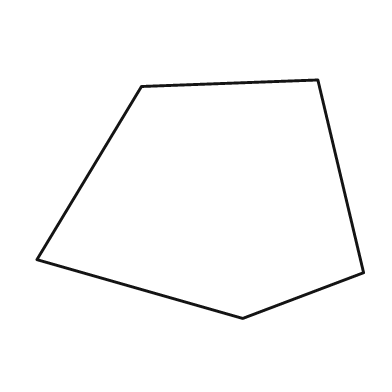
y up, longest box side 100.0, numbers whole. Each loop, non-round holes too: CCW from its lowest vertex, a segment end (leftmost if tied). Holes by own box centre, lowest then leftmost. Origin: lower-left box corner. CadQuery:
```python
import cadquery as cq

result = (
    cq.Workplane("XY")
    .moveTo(63.0, 0.0)
    .lineTo(100.0, 14.0)
    .lineTo(86.0, 73.0)
    .lineTo(32.0, 71.0)
    .lineTo(0.0, 18.0)
    .close()
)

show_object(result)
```